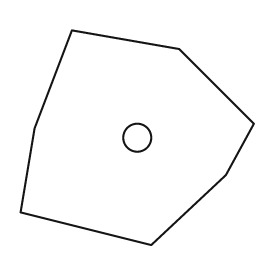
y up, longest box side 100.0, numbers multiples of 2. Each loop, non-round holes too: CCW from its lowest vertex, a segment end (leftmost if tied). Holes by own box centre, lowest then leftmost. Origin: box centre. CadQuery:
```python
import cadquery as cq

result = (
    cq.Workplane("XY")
    .moveTo(6.0, -46.0)
    .lineTo(38.0, -16.0)
    .lineTo(50.0, 6.0)
    .lineTo(18.0, 38.0)
    .lineTo(-28.0, 46.0)
    .lineTo(-44.0, 4.0)
    .lineTo(-50.0, -32.0)
    .close()
    .moveTo(0.0, 0.0)
    .circle(6.0)
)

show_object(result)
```